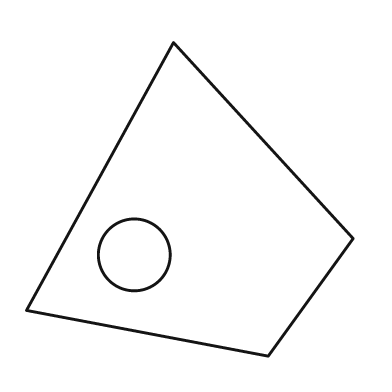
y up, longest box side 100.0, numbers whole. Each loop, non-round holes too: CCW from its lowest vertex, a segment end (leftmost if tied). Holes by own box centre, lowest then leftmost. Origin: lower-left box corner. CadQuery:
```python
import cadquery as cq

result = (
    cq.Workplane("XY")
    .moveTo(74.0, 0.0)
    .lineTo(100.0, 36.0)
    .lineTo(45.0, 96.0)
    .lineTo(0.0, 14.0)
    .close()
    .moveTo(33.0, 31.0)
    .circle(11.0)
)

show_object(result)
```